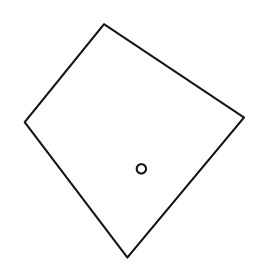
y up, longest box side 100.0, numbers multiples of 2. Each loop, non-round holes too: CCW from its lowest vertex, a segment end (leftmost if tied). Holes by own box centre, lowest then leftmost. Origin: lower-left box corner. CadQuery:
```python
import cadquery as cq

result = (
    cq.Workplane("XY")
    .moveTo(44.0, 0.0)
    .lineTo(94.0, 60.0)
    .lineTo(34.0, 100.0)
    .lineTo(0.0, 58.0)
    .close()
    .moveTo(50.0, 38.0)
    .circle(2.0)
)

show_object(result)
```